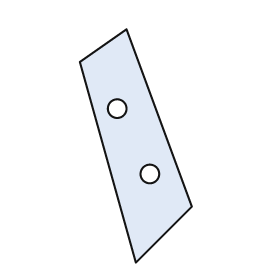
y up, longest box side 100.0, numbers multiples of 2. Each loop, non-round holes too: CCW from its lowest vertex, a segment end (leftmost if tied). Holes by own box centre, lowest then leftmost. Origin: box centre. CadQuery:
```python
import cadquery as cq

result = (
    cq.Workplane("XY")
    .moveTo(0.0, -50.0)
    .lineTo(24.0, -26.0)
    .lineTo(-4.0, 50.0)
    .lineTo(-24.0, 36.0)
    .close()
    .moveTo(6.0, -12.0)
    .circle(4.0)
    .moveTo(-8.0, 16.0)
    .circle(4.0)
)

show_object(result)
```